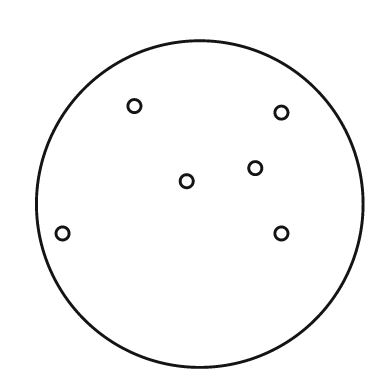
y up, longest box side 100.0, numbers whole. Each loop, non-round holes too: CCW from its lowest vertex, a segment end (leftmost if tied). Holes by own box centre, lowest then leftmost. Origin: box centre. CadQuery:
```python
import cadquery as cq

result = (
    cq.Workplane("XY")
    .moveTo(0.0, 0.0)
    .circle(50.0)
    .moveTo(-42.0, -9.0)
    .circle(2.0)
    .moveTo(25.0, -9.0)
    .circle(2.0)
    .moveTo(-4.0, 7.0)
    .circle(2.0)
    .moveTo(17.0, 11.0)
    .circle(2.0)
    .moveTo(25.0, 28.0)
    .circle(2.0)
    .moveTo(-20.0, 30.0)
    .circle(2.0)
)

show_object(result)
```